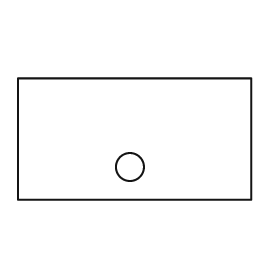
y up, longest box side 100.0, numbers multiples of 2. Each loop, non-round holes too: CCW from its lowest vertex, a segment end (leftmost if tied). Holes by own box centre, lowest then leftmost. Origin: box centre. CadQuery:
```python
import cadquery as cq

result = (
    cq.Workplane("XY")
    .moveTo(-50.0, -26.0)
    .lineTo(50.0, -26.0)
    .lineTo(50.0, 26.0)
    .lineTo(-50.0, 26.0)
    .close()
    .moveTo(-2.0, -12.0)
    .circle(6.0)
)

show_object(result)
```